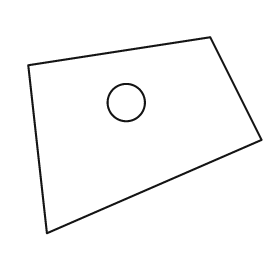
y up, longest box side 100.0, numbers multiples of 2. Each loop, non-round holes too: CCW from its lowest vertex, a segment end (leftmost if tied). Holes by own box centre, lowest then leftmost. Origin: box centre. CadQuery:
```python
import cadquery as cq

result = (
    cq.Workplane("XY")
    .moveTo(-42.0, -42.0)
    .lineTo(50.0, -2.0)
    .lineTo(28.0, 42.0)
    .lineTo(-50.0, 30.0)
    .close()
    .moveTo(-8.0, 14.0)
    .circle(8.0)
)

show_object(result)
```